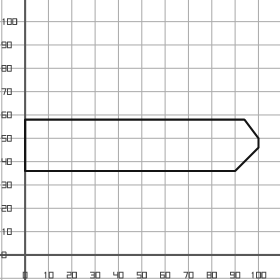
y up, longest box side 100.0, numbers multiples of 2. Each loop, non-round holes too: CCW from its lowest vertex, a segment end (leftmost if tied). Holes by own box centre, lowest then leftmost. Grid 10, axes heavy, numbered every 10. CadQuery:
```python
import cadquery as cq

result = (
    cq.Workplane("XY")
    .moveTo(0.0, 36.0)
    .lineTo(90.0, 36.0)
    .lineTo(100.0, 46.0)
    .lineTo(100.0, 50.0)
    .lineTo(94.0, 58.0)
    .lineTo(0.0, 58.0)
    .close()
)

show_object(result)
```